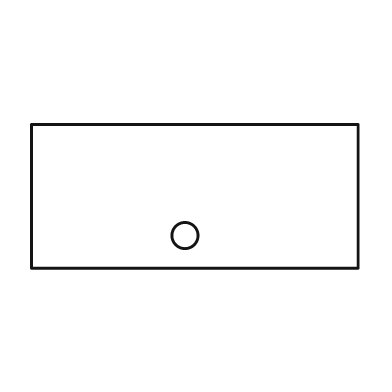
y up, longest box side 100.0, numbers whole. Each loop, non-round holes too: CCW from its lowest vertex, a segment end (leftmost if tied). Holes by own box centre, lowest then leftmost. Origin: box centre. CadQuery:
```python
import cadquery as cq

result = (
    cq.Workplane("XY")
    .moveTo(-50.0, -22.0)
    .lineTo(50.0, -22.0)
    .lineTo(50.0, 22.0)
    .lineTo(-50.0, 22.0)
    .close()
    .moveTo(-3.0, -12.0)
    .circle(4.0)
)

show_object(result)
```